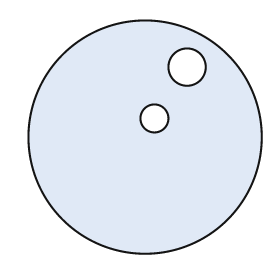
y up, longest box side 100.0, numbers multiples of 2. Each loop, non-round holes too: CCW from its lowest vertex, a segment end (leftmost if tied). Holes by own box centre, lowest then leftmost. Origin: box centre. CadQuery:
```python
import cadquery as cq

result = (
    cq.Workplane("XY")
    .moveTo(0.0, 0.0)
    .circle(50.0)
    .moveTo(4.0, 8.0)
    .circle(6.0)
    .moveTo(18.0, 30.0)
    .circle(8.0)
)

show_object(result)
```